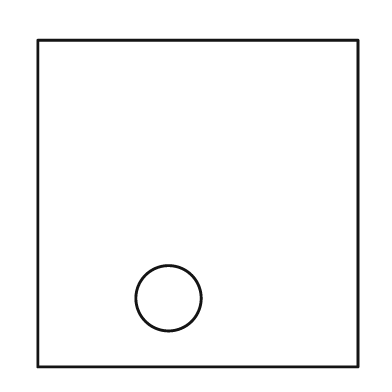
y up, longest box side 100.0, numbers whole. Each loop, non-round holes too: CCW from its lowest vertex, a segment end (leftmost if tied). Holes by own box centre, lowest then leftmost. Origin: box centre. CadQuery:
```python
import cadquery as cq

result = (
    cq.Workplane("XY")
    .moveTo(-49.0, -50.0)
    .lineTo(49.0, -50.0)
    .lineTo(49.0, 50.0)
    .lineTo(-49.0, 50.0)
    .close()
    .moveTo(-9.0, -29.0)
    .circle(10.0)
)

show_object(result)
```